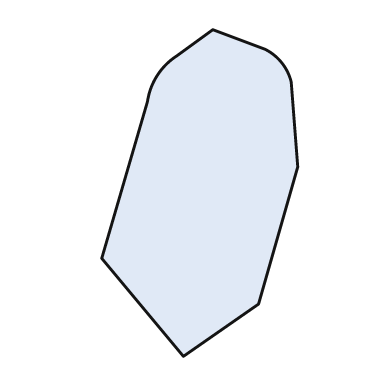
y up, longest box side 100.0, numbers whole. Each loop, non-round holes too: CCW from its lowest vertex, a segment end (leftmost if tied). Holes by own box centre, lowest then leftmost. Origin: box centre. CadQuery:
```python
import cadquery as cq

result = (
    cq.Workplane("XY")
    .moveTo(-5.0, -50.0)
    .lineTo(18.0, -34.0)
    .lineTo(30.0, 8.0)
    .lineTo(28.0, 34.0)
    .threePointArc((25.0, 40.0), (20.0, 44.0))
    .lineTo(4.0, 50.0)
    .lineTo(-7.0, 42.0)
    .threePointArc((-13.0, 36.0), (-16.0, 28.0))
    .lineTo(-30.0, -20.0)
    .close()
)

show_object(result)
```